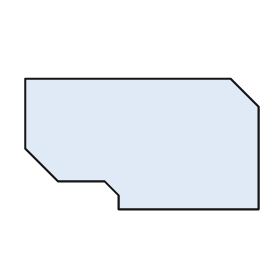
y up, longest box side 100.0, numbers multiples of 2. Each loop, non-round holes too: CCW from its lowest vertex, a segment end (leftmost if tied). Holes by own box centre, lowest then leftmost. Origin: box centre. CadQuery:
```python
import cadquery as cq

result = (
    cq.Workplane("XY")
    .moveTo(-10.0, -28.0)
    .lineTo(50.0, -28.0)
    .lineTo(50.0, 16.0)
    .lineTo(38.0, 28.0)
    .lineTo(-50.0, 28.0)
    .lineTo(-50.0, -2.0)
    .lineTo(-36.0, -16.0)
    .lineTo(-16.0, -16.0)
    .lineTo(-10.0, -22.0)
    .close()
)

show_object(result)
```